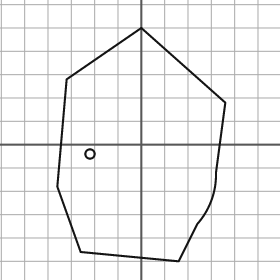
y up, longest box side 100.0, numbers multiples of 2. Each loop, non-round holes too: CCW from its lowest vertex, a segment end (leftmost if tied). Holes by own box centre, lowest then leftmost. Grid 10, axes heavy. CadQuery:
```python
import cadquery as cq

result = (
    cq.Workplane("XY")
    .moveTo(16.0, -50.0)
    .lineTo(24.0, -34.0)
    .threePointArc((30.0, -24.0), (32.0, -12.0))
    .lineTo(36.0, 18.0)
    .lineTo(0.0, 50.0)
    .lineTo(-32.0, 28.0)
    .lineTo(-36.0, -18.0)
    .lineTo(-26.0, -46.0)
    .close()
    .moveTo(-22.0, -4.0)
    .circle(2.0)
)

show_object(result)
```